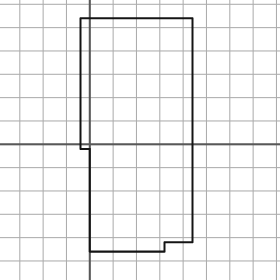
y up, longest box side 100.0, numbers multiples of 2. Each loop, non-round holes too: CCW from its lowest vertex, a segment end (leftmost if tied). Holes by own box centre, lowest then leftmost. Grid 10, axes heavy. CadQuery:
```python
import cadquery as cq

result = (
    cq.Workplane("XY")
    .moveTo(0.0, -46.0)
    .lineTo(32.0, -46.0)
    .lineTo(32.0, -42.0)
    .lineTo(44.0, -42.0)
    .lineTo(44.0, 54.0)
    .lineTo(-4.0, 54.0)
    .lineTo(-4.0, -2.0)
    .lineTo(0.0, -2.0)
    .close()
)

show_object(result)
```